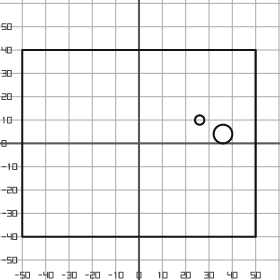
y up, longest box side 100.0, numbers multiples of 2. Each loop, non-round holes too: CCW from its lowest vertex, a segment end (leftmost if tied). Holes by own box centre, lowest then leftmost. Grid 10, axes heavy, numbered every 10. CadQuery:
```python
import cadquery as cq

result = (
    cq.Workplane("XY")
    .moveTo(-50.0, -40.0)
    .lineTo(50.0, -40.0)
    .lineTo(50.0, 40.0)
    .lineTo(-50.0, 40.0)
    .close()
    .moveTo(36.0, 4.0)
    .circle(4.0)
    .moveTo(26.0, 10.0)
    .circle(2.0)
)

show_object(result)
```